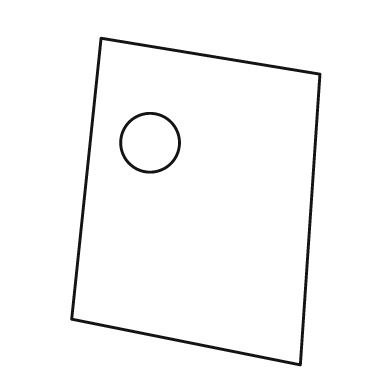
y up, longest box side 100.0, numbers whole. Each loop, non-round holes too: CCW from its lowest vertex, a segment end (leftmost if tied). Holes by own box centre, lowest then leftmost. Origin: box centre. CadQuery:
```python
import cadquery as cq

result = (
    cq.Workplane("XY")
    .moveTo(32.0, -50.0)
    .lineTo(38.0, 39.0)
    .lineTo(-29.0, 50.0)
    .lineTo(-38.0, -36.0)
    .close()
    .moveTo(-14.0, 18.0)
    .circle(9.0)
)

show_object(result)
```